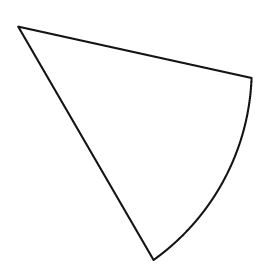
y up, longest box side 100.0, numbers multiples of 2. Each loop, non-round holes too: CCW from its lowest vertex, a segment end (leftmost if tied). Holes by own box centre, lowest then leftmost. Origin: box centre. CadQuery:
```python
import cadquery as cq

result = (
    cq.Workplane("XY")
    .moveTo(8.0, -50.0)
    .threePointArc((38.0, -16.0), (50.0, 28.0))
    .lineTo(-50.0, 50.0)
    .close()
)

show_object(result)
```